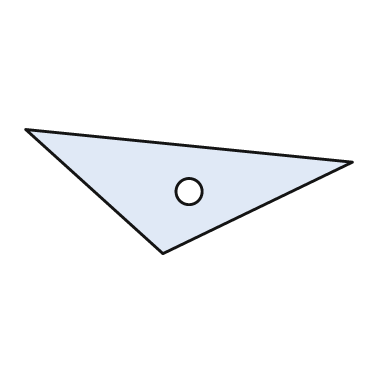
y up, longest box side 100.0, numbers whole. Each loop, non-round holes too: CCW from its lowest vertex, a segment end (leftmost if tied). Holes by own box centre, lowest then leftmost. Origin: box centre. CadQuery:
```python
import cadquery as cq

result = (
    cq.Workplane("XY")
    .moveTo(-8.0, -19.0)
    .lineTo(50.0, 9.0)
    .lineTo(-50.0, 19.0)
    .close()
    .moveTo(0.0, 0.0)
    .circle(4.0)
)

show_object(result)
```